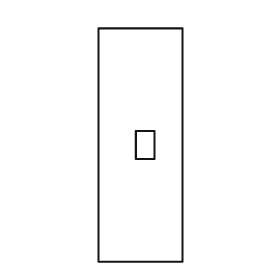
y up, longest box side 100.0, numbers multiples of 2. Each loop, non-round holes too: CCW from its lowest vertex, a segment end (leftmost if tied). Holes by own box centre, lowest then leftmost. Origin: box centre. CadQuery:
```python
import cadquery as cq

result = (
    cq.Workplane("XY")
    .moveTo(-18.0, -50.0)
    .lineTo(18.0, -50.0)
    .lineTo(18.0, 50.0)
    .lineTo(-18.0, 50.0)
    .close()
    .moveTo(-2.0, -6.0)
    .lineTo(6.0, -6.0)
    .lineTo(6.0, 6.0)
    .lineTo(-2.0, 6.0)
    .close()
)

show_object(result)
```